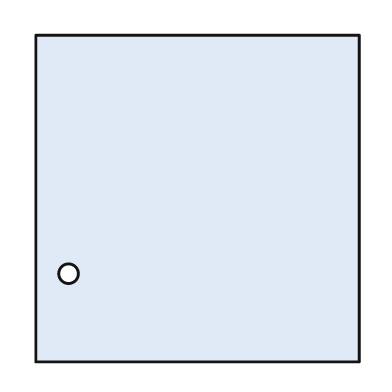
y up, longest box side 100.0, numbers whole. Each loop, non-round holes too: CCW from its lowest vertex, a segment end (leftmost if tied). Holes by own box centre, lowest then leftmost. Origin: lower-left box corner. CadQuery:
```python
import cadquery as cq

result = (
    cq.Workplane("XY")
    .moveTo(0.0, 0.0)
    .lineTo(99.0, 0.0)
    .lineTo(99.0, 100.0)
    .lineTo(0.0, 100.0)
    .close()
    .moveTo(10.0, 27.0)
    .circle(3.0)
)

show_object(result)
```